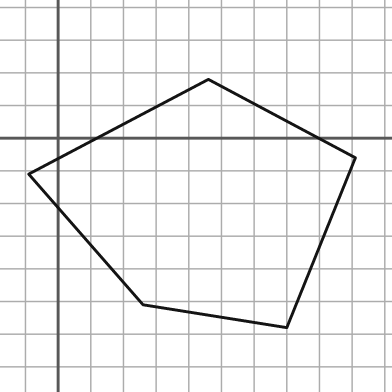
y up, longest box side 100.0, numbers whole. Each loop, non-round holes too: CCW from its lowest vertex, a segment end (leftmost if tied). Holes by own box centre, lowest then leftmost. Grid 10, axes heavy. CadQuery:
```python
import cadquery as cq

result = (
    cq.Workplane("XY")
    .moveTo(70.0, -58.0)
    .lineTo(91.0, -6.0)
    .lineTo(46.0, 18.0)
    .lineTo(-9.0, -11.0)
    .lineTo(26.0, -51.0)
    .close()
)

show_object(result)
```